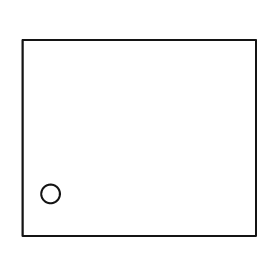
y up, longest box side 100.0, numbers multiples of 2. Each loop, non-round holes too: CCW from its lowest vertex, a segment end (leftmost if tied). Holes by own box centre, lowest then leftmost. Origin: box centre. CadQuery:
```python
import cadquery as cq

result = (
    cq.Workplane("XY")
    .moveTo(-50.0, -42.0)
    .lineTo(50.0, -42.0)
    .lineTo(50.0, 42.0)
    .lineTo(-50.0, 42.0)
    .close()
    .moveTo(-38.0, -24.0)
    .circle(4.0)
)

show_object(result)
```